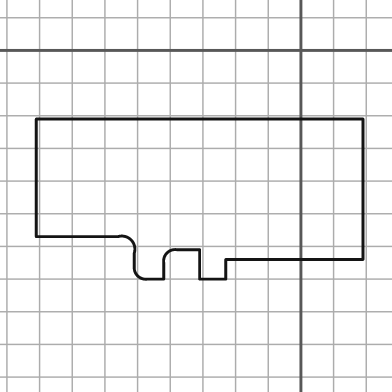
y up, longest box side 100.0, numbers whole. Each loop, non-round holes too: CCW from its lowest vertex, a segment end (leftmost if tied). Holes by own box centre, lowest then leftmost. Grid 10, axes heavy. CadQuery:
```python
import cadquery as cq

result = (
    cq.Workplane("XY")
    .moveTo(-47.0, -70.0)
    .lineTo(-42.0, -70.0)
    .lineTo(-42.0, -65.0)
    .threePointArc((-41.0, -62.0), (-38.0, -61.0))
    .lineTo(-31.0, -61.0)
    .lineTo(-31.0, -70.0)
    .lineTo(-23.0, -70.0)
    .lineTo(-23.0, -64.0)
    .lineTo(19.0, -64.0)
    .lineTo(19.0, -21.0)
    .lineTo(-81.0, -21.0)
    .lineTo(-81.0, -57.0)
    .lineTo(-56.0, -57.0)
    .threePointArc((-52.0, -58.0), (-51.0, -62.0))
    .lineTo(-51.0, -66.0)
    .threePointArc((-50.0, -69.0), (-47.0, -70.0))
    .close()
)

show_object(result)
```